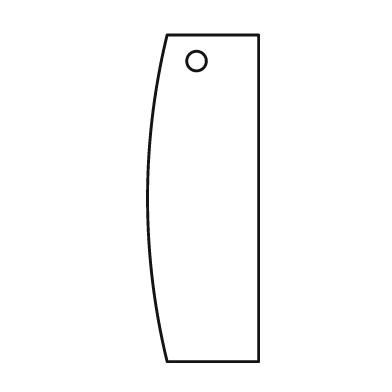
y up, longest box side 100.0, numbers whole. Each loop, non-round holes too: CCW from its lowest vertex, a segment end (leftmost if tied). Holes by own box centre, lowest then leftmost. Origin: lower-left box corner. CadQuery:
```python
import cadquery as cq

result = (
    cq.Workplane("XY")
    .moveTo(6.0, 0.0)
    .lineTo(34.0, 0.0)
    .lineTo(34.0, 100.0)
    .lineTo(6.0, 100.0)
    .threePointArc((0.0, 50.0), (6.0, 0.0))
    .close()
    .moveTo(15.0, 92.0)
    .circle(3.0)
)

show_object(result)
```